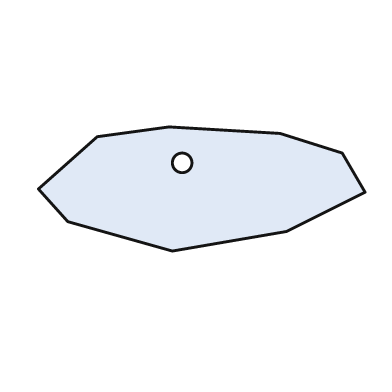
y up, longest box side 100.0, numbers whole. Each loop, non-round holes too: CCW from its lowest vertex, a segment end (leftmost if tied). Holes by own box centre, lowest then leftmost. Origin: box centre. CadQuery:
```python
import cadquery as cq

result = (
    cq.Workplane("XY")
    .moveTo(-9.0, -19.0)
    .lineTo(26.0, -13.0)
    .lineTo(50.0, -1.0)
    .lineTo(43.0, 11.0)
    .lineTo(24.0, 17.0)
    .lineTo(-10.0, 19.0)
    .lineTo(-32.0, 16.0)
    .lineTo(-50.0, 0.0)
    .lineTo(-41.0, -10.0)
    .close()
    .moveTo(-6.0, 8.0)
    .circle(3.0)
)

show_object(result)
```